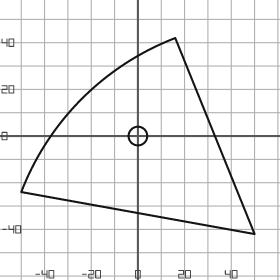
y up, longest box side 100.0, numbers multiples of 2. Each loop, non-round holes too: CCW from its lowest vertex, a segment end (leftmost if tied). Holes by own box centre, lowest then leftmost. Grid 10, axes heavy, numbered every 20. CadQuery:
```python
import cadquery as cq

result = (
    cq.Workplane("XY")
    .moveTo(50.0, -42.0)
    .lineTo(16.0, 42.0)
    .threePointArc((-24.0, 16.0), (-50.0, -24.0))
    .close()
    .moveTo(0.0, 0.0)
    .circle(4.0)
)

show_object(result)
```